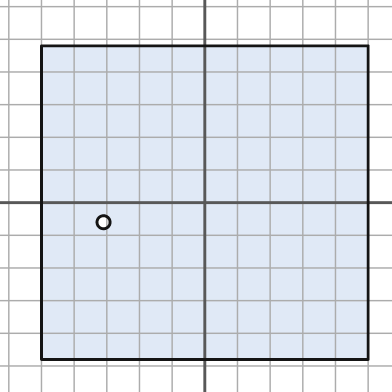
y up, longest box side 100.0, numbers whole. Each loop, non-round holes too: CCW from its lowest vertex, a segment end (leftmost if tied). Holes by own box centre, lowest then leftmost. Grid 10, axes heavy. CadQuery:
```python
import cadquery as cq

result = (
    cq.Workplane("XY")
    .moveTo(-50.0, -48.0)
    .lineTo(50.0, -48.0)
    .lineTo(50.0, 48.0)
    .lineTo(-50.0, 48.0)
    .close()
    .moveTo(-31.0, -6.0)
    .circle(2.0)
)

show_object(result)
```